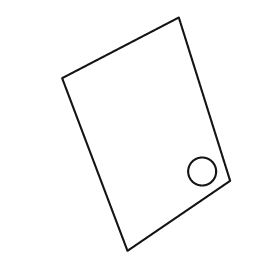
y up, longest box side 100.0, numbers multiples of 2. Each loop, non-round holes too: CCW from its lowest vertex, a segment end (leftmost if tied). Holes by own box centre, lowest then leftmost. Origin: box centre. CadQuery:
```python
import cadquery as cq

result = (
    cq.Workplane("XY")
    .moveTo(-8.0, -50.0)
    .lineTo(36.0, -20.0)
    .lineTo(14.0, 50.0)
    .lineTo(-36.0, 24.0)
    .close()
    .moveTo(24.0, -16.0)
    .circle(6.0)
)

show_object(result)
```